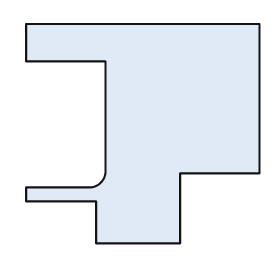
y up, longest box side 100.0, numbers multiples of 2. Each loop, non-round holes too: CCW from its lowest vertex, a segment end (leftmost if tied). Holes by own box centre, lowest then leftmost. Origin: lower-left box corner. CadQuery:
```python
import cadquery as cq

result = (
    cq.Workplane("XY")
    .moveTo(30.0, 0.0)
    .lineTo(66.0, 0.0)
    .lineTo(66.0, 30.0)
    .lineTo(100.0, 30.0)
    .lineTo(100.0, 94.0)
    .lineTo(0.0, 94.0)
    .lineTo(0.0, 78.0)
    .lineTo(34.0, 78.0)
    .lineTo(34.0, 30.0)
    .threePointArc((32.0, 26.0), (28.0, 24.0))
    .lineTo(0.0, 24.0)
    .lineTo(0.0, 18.0)
    .lineTo(30.0, 18.0)
    .close()
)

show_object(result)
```